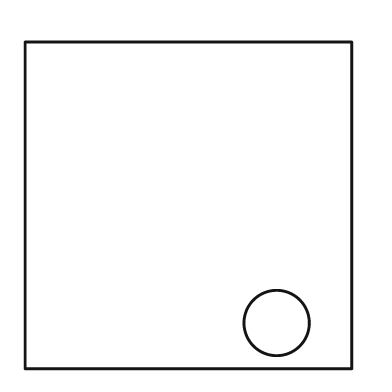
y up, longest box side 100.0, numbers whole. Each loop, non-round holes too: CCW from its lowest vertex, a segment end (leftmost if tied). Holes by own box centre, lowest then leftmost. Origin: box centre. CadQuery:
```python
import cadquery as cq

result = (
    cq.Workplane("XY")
    .moveTo(-50.0, -50.0)
    .lineTo(50.0, -50.0)
    .lineTo(50.0, 50.0)
    .lineTo(-50.0, 50.0)
    .close()
    .moveTo(27.0, -36.0)
    .circle(10.0)
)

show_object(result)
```